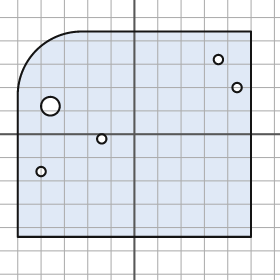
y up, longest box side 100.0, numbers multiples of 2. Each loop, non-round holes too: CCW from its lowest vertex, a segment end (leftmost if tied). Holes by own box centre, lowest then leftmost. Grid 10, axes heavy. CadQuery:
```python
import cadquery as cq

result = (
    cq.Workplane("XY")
    .moveTo(-50.0, -44.0)
    .lineTo(50.0, -44.0)
    .lineTo(50.0, 44.0)
    .lineTo(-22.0, 44.0)
    .threePointArc((-42.0, 36.0), (-50.0, 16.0))
    .close()
    .moveTo(-40.0, -16.0)
    .circle(2.0)
    .moveTo(-14.0, -2.0)
    .circle(2.0)
    .moveTo(-36.0, 12.0)
    .circle(4.0)
    .moveTo(44.0, 20.0)
    .circle(2.0)
    .moveTo(36.0, 32.0)
    .circle(2.0)
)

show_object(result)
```